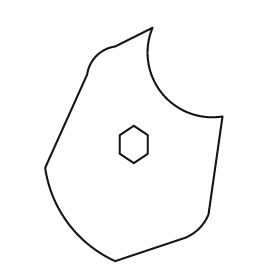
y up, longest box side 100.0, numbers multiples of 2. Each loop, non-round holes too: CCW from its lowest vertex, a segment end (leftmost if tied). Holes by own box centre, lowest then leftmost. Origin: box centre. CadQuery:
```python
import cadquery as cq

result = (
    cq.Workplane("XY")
    .moveTo(-8.0, -50.0)
    .lineTo(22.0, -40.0)
    .threePointArc((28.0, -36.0), (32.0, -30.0))
    .lineTo(38.0, 12.0)
    .threePointArc((12.0, 22.0), (8.0, 50.0))
    .lineTo(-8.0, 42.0)
    .threePointArc((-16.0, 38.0), (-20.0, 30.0))
    .lineTo(-38.0, -10.0)
    .threePointArc((-28.0, -34.0), (-8.0, -50.0))
    .close()
    .moveTo(0.0, -8.0)
    .lineTo(6.0, -4.0)
    .lineTo(6.0, 4.0)
    .lineTo(0.0, 8.0)
    .lineTo(-6.0, 4.0)
    .lineTo(-6.0, -4.0)
    .close()
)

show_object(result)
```